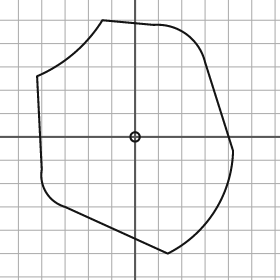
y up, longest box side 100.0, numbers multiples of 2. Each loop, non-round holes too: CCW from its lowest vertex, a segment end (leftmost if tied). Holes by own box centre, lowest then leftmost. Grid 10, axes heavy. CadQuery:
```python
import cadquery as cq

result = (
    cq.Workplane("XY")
    .moveTo(14.0, -50.0)
    .threePointArc((34.0, -32.0), (42.0, -6.0))
    .lineTo(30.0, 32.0)
    .threePointArc((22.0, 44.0), (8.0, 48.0))
    .lineTo(-14.0, 50.0)
    .threePointArc((-26.0, 36.0), (-42.0, 26.0))
    .lineTo(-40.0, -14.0)
    .threePointArc((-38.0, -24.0), (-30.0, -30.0))
    .close()
    .moveTo(0.0, 0.0)
    .circle(2.0)
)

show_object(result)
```